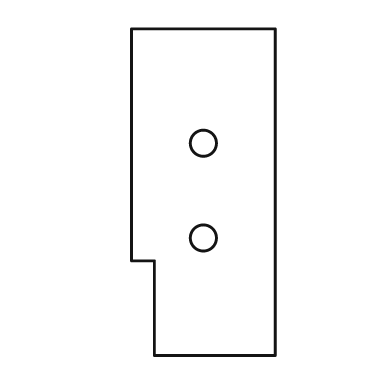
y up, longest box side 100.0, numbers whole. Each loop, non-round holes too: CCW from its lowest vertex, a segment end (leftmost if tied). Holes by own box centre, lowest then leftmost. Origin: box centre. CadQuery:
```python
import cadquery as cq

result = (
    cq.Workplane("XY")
    .moveTo(-15.0, -50.0)
    .lineTo(22.0, -50.0)
    .lineTo(22.0, 50.0)
    .lineTo(-22.0, 50.0)
    .lineTo(-22.0, -21.0)
    .lineTo(-15.0, -21.0)
    .close()
    .moveTo(0.0, -14.0)
    .circle(4.0)
    .moveTo(0.0, 15.0)
    .circle(4.0)
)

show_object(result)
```